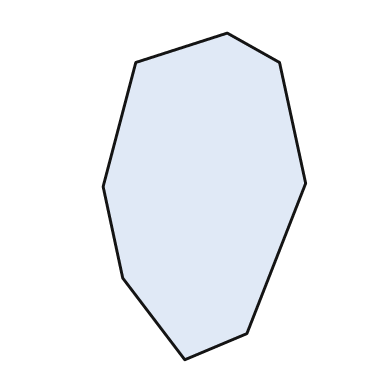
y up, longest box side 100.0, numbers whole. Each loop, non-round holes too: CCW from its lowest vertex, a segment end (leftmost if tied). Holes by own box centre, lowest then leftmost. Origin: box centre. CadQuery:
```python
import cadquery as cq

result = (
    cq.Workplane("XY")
    .moveTo(-6.0, -50.0)
    .lineTo(13.0, -42.0)
    .lineTo(31.0, 4.0)
    .lineTo(23.0, 41.0)
    .lineTo(7.0, 50.0)
    .lineTo(-21.0, 41.0)
    .lineTo(-31.0, 3.0)
    .lineTo(-25.0, -25.0)
    .close()
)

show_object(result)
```